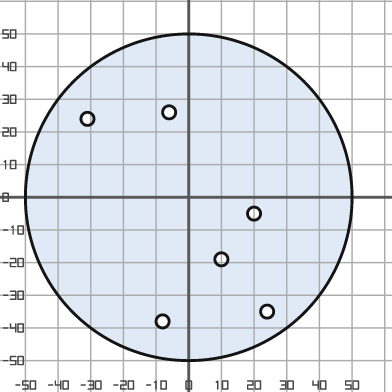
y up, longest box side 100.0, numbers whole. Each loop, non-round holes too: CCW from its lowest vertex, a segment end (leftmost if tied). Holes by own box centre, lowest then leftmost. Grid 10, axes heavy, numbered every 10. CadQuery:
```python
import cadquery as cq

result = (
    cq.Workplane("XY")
    .moveTo(0.0, 0.0)
    .circle(50.0)
    .moveTo(-8.0, -38.0)
    .circle(2.0)
    .moveTo(24.0, -35.0)
    .circle(2.0)
    .moveTo(10.0, -19.0)
    .circle(2.0)
    .moveTo(20.0, -5.0)
    .circle(2.0)
    .moveTo(-31.0, 24.0)
    .circle(2.0)
    .moveTo(-6.0, 26.0)
    .circle(2.0)
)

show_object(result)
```